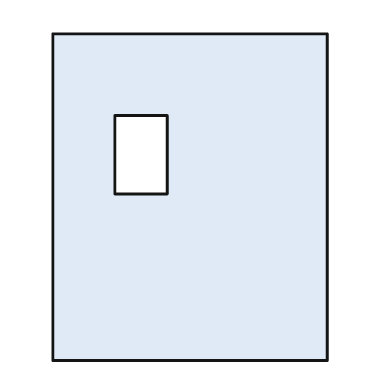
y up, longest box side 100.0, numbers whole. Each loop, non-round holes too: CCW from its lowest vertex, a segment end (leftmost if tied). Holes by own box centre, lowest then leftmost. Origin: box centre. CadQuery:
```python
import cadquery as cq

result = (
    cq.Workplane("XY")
    .moveTo(-42.0, -50.0)
    .lineTo(42.0, -50.0)
    .lineTo(42.0, 50.0)
    .lineTo(-42.0, 50.0)
    .close()
    .moveTo(-23.0, 1.0)
    .lineTo(-7.0, 1.0)
    .lineTo(-7.0, 25.0)
    .lineTo(-23.0, 25.0)
    .close()
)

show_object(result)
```